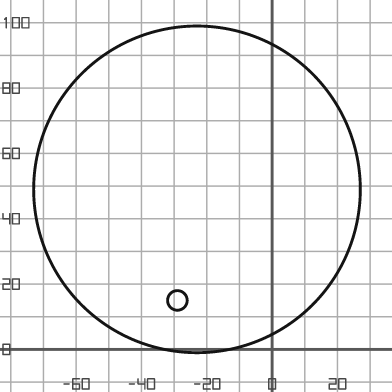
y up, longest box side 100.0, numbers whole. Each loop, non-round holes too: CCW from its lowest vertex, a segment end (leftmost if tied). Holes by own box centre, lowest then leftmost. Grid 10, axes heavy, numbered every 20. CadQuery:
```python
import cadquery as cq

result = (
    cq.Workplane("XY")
    .moveTo(-23.0, 49.0)
    .circle(50.0)
    .moveTo(-29.0, 15.0)
    .circle(3.0)
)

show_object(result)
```